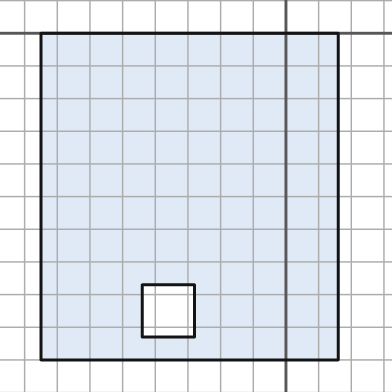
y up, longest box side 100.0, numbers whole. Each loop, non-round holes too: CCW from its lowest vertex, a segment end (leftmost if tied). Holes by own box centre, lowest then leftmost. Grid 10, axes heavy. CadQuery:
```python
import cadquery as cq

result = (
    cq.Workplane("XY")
    .moveTo(-75.0, -100.0)
    .lineTo(16.0, -100.0)
    .lineTo(16.0, 0.0)
    .lineTo(-75.0, 0.0)
    .close()
    .moveTo(-44.0, -93.0)
    .lineTo(-28.0, -93.0)
    .lineTo(-28.0, -77.0)
    .lineTo(-44.0, -77.0)
    .close()
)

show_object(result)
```